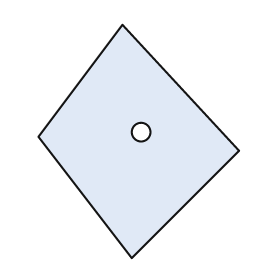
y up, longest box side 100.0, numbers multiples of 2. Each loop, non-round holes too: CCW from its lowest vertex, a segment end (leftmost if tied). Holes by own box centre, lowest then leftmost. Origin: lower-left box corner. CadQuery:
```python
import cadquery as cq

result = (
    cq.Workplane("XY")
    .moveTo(40.0, 0.0)
    .lineTo(86.0, 46.0)
    .lineTo(36.0, 100.0)
    .lineTo(0.0, 52.0)
    .close()
    .moveTo(44.0, 54.0)
    .circle(4.0)
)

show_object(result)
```